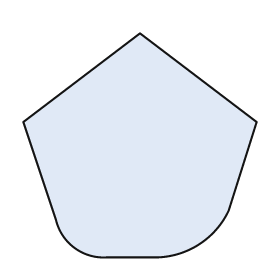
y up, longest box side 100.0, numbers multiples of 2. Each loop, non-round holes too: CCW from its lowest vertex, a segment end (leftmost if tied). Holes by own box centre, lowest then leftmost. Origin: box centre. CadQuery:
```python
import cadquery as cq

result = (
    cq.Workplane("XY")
    .moveTo(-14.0, -48.0)
    .lineTo(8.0, -48.0)
    .threePointArc((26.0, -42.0), (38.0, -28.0))
    .lineTo(50.0, 10.0)
    .lineTo(0.0, 48.0)
    .lineTo(-50.0, 10.0)
    .lineTo(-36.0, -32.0)
    .threePointArc((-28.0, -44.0), (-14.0, -48.0))
    .close()
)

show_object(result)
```